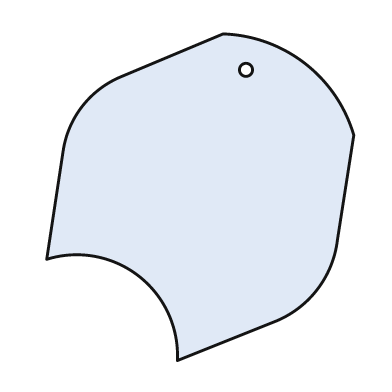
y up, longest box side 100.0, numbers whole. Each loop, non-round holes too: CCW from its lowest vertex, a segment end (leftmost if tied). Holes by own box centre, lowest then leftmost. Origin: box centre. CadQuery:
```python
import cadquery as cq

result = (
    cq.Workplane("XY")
    .moveTo(-7.0, -50.0)
    .lineTo(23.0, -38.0)
    .threePointArc((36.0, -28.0), (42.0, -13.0))
    .lineTo(47.0, 19.0)
    .threePointArc((32.0, 41.0), (7.0, 50.0))
    .lineTo(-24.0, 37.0)
    .threePointArc((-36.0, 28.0), (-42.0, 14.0))
    .lineTo(-47.0, -19.0)
    .threePointArc((-19.0, -24.0), (-7.0, -50.0))
    .close()
    .moveTo(14.0, 39.0)
    .circle(2.0)
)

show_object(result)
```